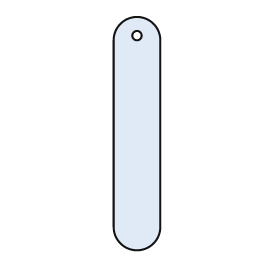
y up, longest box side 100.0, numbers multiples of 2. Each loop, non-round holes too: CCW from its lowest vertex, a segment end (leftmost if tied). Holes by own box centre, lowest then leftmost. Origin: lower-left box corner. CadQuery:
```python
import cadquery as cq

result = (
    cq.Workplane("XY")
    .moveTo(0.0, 10.0)
    .threePointArc((10.0, 0.0), (20.0, 10.0))
    .lineTo(20.0, 90.0)
    .threePointArc((10.0, 100.0), (0.0, 90.0))
    .close()
    .moveTo(10.0, 92.0)
    .circle(2.0)
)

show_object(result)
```